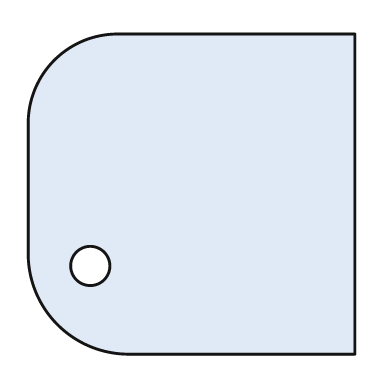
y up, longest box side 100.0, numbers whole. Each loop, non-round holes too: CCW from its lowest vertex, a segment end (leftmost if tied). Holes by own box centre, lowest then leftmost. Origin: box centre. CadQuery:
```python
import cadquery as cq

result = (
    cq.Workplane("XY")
    .moveTo(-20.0, -49.0)
    .lineTo(50.0, -49.0)
    .lineTo(50.0, 49.0)
    .lineTo(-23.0, 49.0)
    .threePointArc((-42.0, 41.0), (-50.0, 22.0))
    .lineTo(-50.0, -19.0)
    .threePointArc((-41.0, -40.0), (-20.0, -49.0))
    .close()
    .moveTo(-31.0, -22.0)
    .circle(6.0)
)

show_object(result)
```